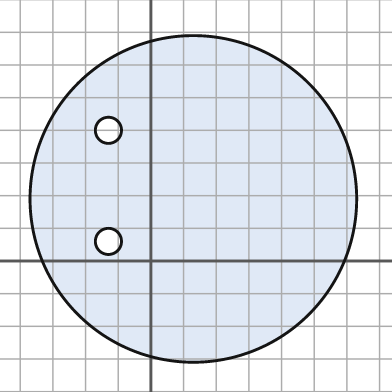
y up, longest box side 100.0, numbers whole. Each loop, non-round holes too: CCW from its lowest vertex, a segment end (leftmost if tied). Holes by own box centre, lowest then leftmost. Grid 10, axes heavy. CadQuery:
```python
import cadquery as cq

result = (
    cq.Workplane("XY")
    .moveTo(13.0, 19.0)
    .circle(50.0)
    .moveTo(-13.0, 6.0)
    .circle(4.0)
    .moveTo(-13.0, 40.0)
    .circle(4.0)
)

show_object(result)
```